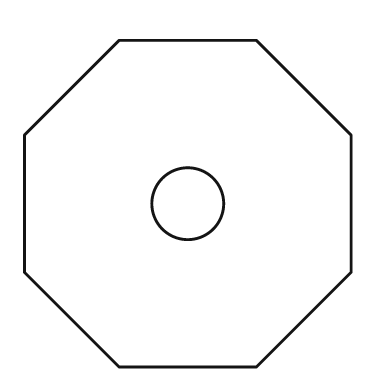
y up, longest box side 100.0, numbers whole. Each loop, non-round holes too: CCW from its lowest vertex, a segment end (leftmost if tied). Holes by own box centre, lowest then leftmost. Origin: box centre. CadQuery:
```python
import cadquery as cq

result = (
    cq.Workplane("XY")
    .moveTo(-21.0, -50.0)
    .lineTo(21.0, -50.0)
    .lineTo(50.0, -21.0)
    .lineTo(50.0, 21.0)
    .lineTo(21.0, 50.0)
    .lineTo(-21.0, 50.0)
    .lineTo(-50.0, 21.0)
    .lineTo(-50.0, -21.0)
    .close()
    .moveTo(0.0, 0.0)
    .circle(11.0)
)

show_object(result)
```